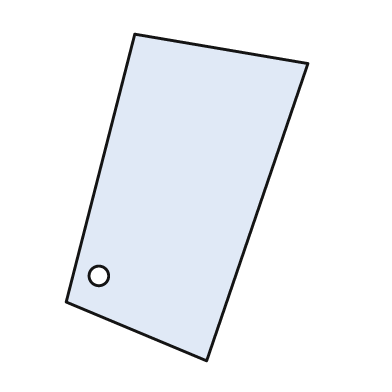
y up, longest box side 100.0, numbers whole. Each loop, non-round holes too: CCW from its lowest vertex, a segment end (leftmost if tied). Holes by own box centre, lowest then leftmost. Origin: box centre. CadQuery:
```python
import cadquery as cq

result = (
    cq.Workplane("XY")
    .moveTo(6.0, -50.0)
    .lineTo(37.0, 41.0)
    .lineTo(-16.0, 50.0)
    .lineTo(-37.0, -32.0)
    .close()
    .moveTo(-27.0, -24.0)
    .circle(3.0)
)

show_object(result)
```